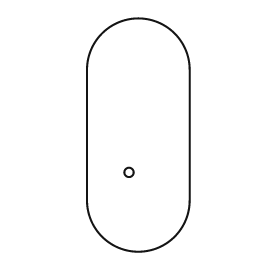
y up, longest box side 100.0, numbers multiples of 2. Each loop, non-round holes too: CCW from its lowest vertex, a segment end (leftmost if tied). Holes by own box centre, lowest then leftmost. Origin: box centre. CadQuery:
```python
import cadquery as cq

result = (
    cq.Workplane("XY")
    .moveTo(-22.0, -28.0)
    .threePointArc((0.0, -50.0), (22.0, -28.0))
    .lineTo(22.0, 28.0)
    .threePointArc((0.0, 50.0), (-22.0, 28.0))
    .close()
    .moveTo(-4.0, -16.0)
    .circle(2.0)
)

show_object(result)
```